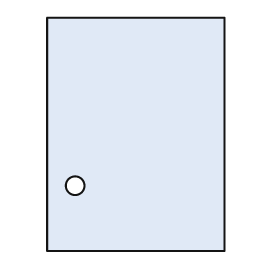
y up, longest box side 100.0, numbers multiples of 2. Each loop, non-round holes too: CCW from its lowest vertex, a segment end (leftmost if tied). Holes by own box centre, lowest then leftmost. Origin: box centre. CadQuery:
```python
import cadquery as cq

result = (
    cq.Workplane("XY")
    .moveTo(-38.0, -50.0)
    .lineTo(38.0, -50.0)
    .lineTo(38.0, 50.0)
    .lineTo(-38.0, 50.0)
    .close()
    .moveTo(-26.0, -22.0)
    .circle(4.0)
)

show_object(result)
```